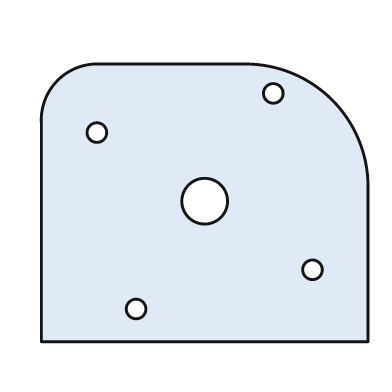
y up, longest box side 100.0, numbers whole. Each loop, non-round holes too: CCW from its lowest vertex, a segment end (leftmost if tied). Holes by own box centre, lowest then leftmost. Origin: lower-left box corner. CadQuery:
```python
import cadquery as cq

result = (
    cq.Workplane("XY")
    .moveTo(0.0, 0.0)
    .lineTo(100.0, 0.0)
    .lineTo(100.0, 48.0)
    .threePointArc((89.0, 74.0), (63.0, 85.0))
    .lineTo(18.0, 85.0)
    .threePointArc((5.0, 80.0), (0.0, 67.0))
    .close()
    .moveTo(29.0, 10.0)
    .circle(3.0)
    .moveTo(83.0, 22.0)
    .circle(3.0)
    .moveTo(50.0, 43.0)
    .circle(7.0)
    .moveTo(17.0, 64.0)
    .circle(3.0)
    .moveTo(71.0, 76.0)
    .circle(3.0)
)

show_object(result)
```